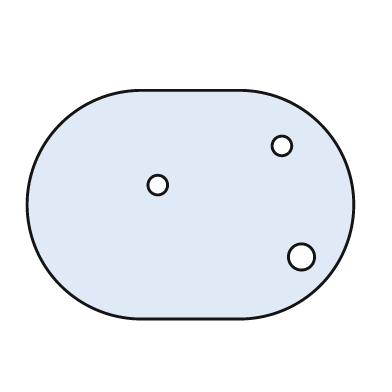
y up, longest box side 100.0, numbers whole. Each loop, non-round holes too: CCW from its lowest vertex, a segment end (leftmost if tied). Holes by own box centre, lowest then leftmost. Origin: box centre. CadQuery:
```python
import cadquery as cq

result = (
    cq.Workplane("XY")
    .moveTo(-15.0, -35.0)
    .lineTo(15.0, -35.0)
    .threePointArc((50.0, 0.0), (15.0, 35.0))
    .lineTo(-15.0, 35.0)
    .threePointArc((-50.0, 0.0), (-15.0, -35.0))
    .close()
    .moveTo(34.0, -16.0)
    .circle(4.0)
    .moveTo(-10.0, 6.0)
    .circle(3.0)
    .moveTo(28.0, 18.0)
    .circle(3.0)
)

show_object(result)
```